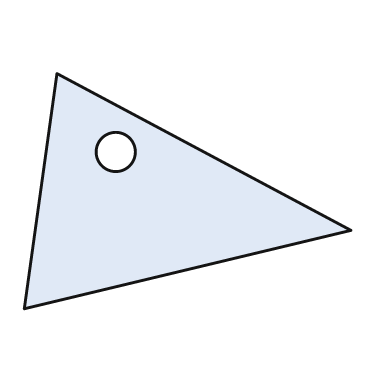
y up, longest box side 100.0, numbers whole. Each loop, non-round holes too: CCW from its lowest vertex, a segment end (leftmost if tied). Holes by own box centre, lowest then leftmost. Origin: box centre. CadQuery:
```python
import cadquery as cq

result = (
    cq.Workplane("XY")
    .moveTo(-50.0, -36.0)
    .lineTo(50.0, -12.0)
    .lineTo(-40.0, 36.0)
    .close()
    .moveTo(-22.0, 12.0)
    .circle(6.0)
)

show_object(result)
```